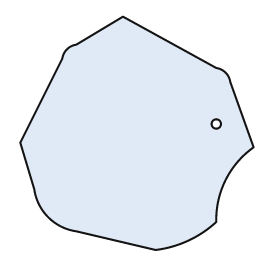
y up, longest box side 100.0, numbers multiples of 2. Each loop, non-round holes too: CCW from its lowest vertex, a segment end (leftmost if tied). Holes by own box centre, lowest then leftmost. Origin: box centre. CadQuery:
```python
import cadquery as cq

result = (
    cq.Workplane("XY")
    .moveTo(8.0, -50.0)
    .threePointArc((22.0, -46.0), (34.0, -38.0))
    .threePointArc((38.0, -20.0), (50.0, -6.0))
    .lineTo(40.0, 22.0)
    .threePointArc((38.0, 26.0), (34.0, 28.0))
    .lineTo(-6.0, 50.0)
    .lineTo(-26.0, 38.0)
    .threePointArc((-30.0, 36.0), (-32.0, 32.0))
    .lineTo(-50.0, -4.0)
    .lineTo(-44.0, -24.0)
    .threePointArc((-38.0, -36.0), (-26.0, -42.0))
    .close()
    .moveTo(34.0, 4.0)
    .circle(2.0)
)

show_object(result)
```